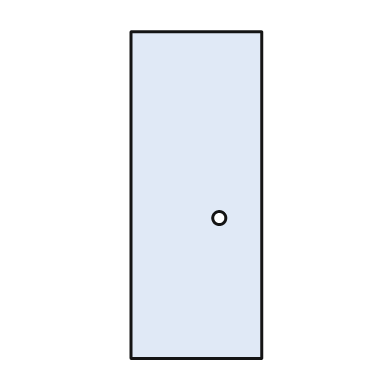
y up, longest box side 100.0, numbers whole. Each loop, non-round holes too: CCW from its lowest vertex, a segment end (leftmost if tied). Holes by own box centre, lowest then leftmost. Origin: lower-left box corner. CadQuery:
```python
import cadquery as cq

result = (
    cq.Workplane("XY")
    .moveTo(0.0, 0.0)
    .lineTo(40.0, 0.0)
    .lineTo(40.0, 100.0)
    .lineTo(0.0, 100.0)
    .close()
    .moveTo(27.0, 43.0)
    .circle(2.0)
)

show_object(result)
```